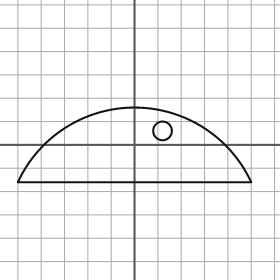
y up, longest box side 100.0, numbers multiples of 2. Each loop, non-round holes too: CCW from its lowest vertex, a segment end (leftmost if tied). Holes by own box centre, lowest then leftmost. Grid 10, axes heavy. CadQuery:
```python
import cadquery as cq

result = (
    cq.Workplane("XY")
    .moveTo(-50.0, -16.0)
    .lineTo(50.0, -16.0)
    .threePointArc((0.0, 16.0), (-50.0, -16.0))
    .close()
    .moveTo(12.0, 6.0)
    .circle(4.0)
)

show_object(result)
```